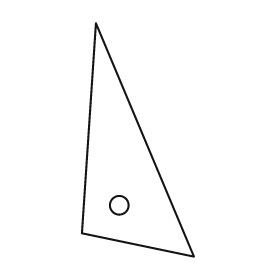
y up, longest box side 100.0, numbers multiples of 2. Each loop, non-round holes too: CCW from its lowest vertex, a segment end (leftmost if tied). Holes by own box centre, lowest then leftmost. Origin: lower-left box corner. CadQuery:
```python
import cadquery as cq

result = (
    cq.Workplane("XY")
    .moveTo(48.0, 0.0)
    .lineTo(6.0, 100.0)
    .lineTo(0.0, 10.0)
    .close()
    .moveTo(16.0, 22.0)
    .circle(4.0)
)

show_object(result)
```